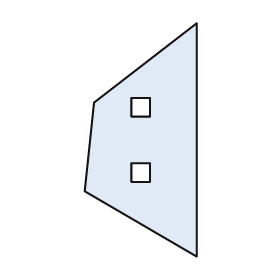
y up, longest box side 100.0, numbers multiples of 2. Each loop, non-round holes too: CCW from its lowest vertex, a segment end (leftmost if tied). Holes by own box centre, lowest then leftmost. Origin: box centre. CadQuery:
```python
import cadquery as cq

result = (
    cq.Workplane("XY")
    .moveTo(24.0, -50.0)
    .lineTo(24.0, 50.0)
    .lineTo(-20.0, 16.0)
    .lineTo(-24.0, -22.0)
    .close()
    .moveTo(-4.0, -18.0)
    .lineTo(4.0, -18.0)
    .lineTo(4.0, -10.0)
    .lineTo(-4.0, -10.0)
    .close()
    .moveTo(-4.0, 10.0)
    .lineTo(4.0, 10.0)
    .lineTo(4.0, 18.0)
    .lineTo(-4.0, 18.0)
    .close()
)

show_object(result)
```